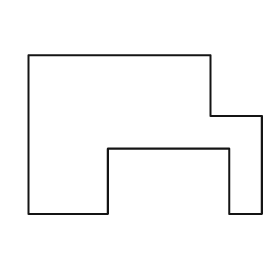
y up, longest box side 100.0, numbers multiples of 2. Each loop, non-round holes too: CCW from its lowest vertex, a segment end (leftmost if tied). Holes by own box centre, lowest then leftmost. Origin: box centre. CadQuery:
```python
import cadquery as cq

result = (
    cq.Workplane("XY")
    .moveTo(-50.0, -34.0)
    .lineTo(-16.0, -34.0)
    .lineTo(-16.0, -6.0)
    .lineTo(36.0, -6.0)
    .lineTo(36.0, -34.0)
    .lineTo(50.0, -34.0)
    .lineTo(50.0, 8.0)
    .lineTo(28.0, 8.0)
    .lineTo(28.0, 34.0)
    .lineTo(-50.0, 34.0)
    .close()
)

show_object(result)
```